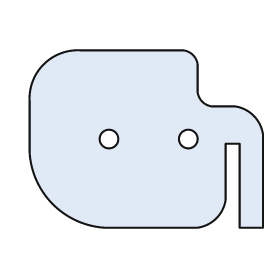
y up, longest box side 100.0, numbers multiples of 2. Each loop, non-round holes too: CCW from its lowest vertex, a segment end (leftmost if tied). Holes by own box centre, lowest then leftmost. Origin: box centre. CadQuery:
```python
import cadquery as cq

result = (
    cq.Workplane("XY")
    .moveTo(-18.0, -38.0)
    .lineTo(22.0, -38.0)
    .threePointArc((30.0, -34.0), (34.0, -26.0))
    .lineTo(34.0, -2.0)
    .lineTo(40.0, -2.0)
    .lineTo(40.0, -38.0)
    .lineTo(50.0, -38.0)
    .lineTo(50.0, 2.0)
    .threePointArc((46.0, 10.0), (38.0, 14.0))
    .lineTo(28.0, 14.0)
    .threePointArc((24.0, 16.0), (22.0, 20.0))
    .lineTo(22.0, 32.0)
    .threePointArc((20.0, 36.0), (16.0, 38.0))
    .lineTo(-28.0, 38.0)
    .threePointArc((-44.0, 32.0), (-50.0, 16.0))
    .lineTo(-50.0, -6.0)
    .threePointArc((-40.0, -28.0), (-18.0, -38.0))
    .close()
    .moveTo(-16.0, 0.0)
    .circle(4.0)
    .moveTo(18.0, 0.0)
    .circle(4.0)
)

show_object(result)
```